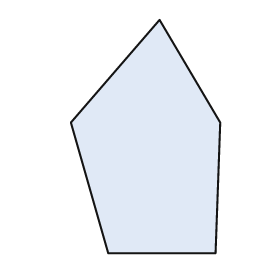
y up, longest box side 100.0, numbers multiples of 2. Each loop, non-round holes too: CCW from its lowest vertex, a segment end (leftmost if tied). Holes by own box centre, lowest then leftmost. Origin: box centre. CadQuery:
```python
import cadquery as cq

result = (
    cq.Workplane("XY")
    .moveTo(-16.0, -50.0)
    .lineTo(30.0, -50.0)
    .lineTo(32.0, 6.0)
    .lineTo(6.0, 50.0)
    .lineTo(-32.0, 6.0)
    .close()
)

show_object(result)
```